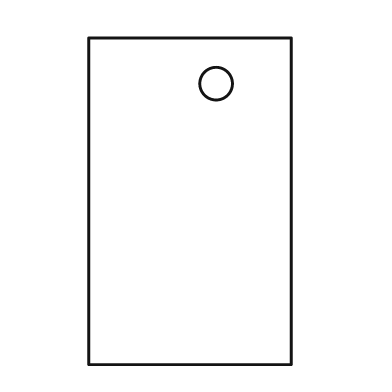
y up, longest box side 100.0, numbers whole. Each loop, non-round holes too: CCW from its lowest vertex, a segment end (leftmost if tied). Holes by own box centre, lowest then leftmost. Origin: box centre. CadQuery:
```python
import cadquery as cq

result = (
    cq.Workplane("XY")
    .moveTo(-31.0, -50.0)
    .lineTo(31.0, -50.0)
    .lineTo(31.0, 50.0)
    .lineTo(-31.0, 50.0)
    .close()
    .moveTo(8.0, 36.0)
    .circle(5.0)
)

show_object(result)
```